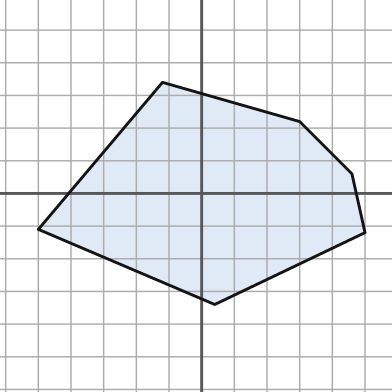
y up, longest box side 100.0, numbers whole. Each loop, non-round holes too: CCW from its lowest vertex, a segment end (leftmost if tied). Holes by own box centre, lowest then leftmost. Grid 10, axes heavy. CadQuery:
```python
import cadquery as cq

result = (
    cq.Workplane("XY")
    .moveTo(4.0, -34.0)
    .lineTo(50.0, -12.0)
    .lineTo(46.0, 6.0)
    .lineTo(30.0, 22.0)
    .lineTo(-12.0, 34.0)
    .lineTo(-50.0, -11.0)
    .close()
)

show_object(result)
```